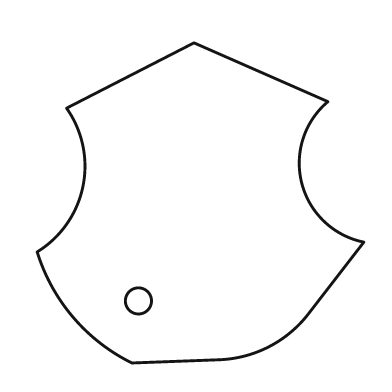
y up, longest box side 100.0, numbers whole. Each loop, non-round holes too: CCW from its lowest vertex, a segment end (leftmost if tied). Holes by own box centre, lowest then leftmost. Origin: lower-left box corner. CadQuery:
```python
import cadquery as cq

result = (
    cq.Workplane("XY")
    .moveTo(29.0, 0.0)
    .lineTo(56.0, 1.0)
    .threePointArc((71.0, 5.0), (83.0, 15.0))
    .lineTo(100.0, 37.0)
    .threePointArc((81.0, 55.0), (89.0, 80.0))
    .lineTo(48.0, 98.0)
    .lineTo(9.0, 78.0)
    .threePointArc((14.0, 54.0), (0.0, 34.0))
    .threePointArc((11.0, 14.0), (29.0, 0.0))
    .close()
    .moveTo(31.0, 19.0)
    .circle(4.0)
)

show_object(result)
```